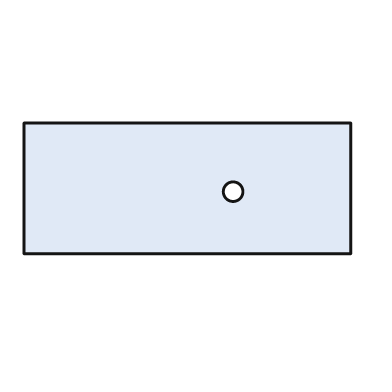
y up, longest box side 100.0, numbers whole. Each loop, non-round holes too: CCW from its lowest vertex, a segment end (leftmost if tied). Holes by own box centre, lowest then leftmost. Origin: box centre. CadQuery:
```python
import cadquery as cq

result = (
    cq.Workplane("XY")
    .moveTo(-50.0, -20.0)
    .lineTo(50.0, -20.0)
    .lineTo(50.0, 20.0)
    .lineTo(-50.0, 20.0)
    .close()
    .moveTo(14.0, -1.0)
    .circle(3.0)
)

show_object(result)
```